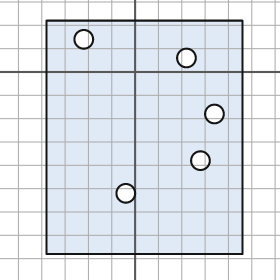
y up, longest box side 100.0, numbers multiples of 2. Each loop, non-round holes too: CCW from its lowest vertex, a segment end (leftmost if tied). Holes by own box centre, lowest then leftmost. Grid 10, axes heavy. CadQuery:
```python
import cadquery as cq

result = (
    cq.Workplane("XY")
    .moveTo(-38.0, -78.0)
    .lineTo(46.0, -78.0)
    .lineTo(46.0, 22.0)
    .lineTo(-38.0, 22.0)
    .close()
    .moveTo(-4.0, -52.0)
    .circle(4.0)
    .moveTo(28.0, -38.0)
    .circle(4.0)
    .moveTo(34.0, -18.0)
    .circle(4.0)
    .moveTo(22.0, 6.0)
    .circle(4.0)
    .moveTo(-22.0, 14.0)
    .circle(4.0)
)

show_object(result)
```